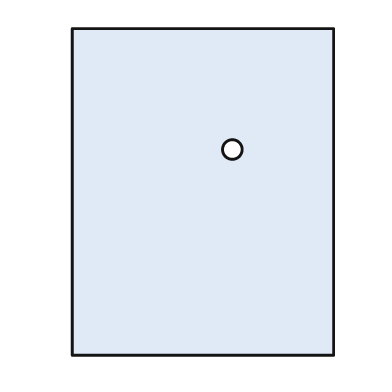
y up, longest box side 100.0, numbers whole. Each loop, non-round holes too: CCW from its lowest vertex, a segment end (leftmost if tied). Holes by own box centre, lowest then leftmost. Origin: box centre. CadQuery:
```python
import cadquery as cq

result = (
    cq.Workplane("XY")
    .moveTo(-40.0, -50.0)
    .lineTo(40.0, -50.0)
    .lineTo(40.0, 50.0)
    .lineTo(-40.0, 50.0)
    .close()
    .moveTo(9.0, 13.0)
    .circle(3.0)
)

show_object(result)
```